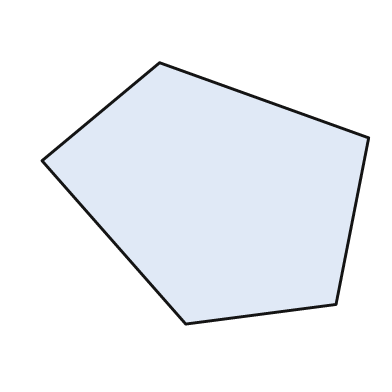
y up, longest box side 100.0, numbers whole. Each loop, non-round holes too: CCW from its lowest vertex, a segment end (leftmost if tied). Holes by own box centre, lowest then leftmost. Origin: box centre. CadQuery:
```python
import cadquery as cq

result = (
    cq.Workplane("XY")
    .moveTo(-6.0, -40.0)
    .lineTo(40.0, -34.0)
    .lineTo(50.0, 17.0)
    .lineTo(-14.0, 40.0)
    .lineTo(-50.0, 10.0)
    .close()
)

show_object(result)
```